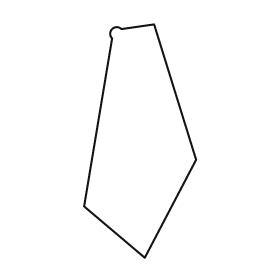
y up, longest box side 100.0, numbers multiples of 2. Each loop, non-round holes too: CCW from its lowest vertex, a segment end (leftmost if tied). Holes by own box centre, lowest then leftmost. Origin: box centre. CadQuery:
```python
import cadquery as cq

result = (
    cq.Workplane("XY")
    .moveTo(2.0, -50.0)
    .lineTo(24.0, -8.0)
    .lineTo(6.0, 50.0)
    .lineTo(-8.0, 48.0)
    .threePointArc((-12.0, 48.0), (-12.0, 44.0))
    .lineTo(-24.0, -28.0)
    .close()
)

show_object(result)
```